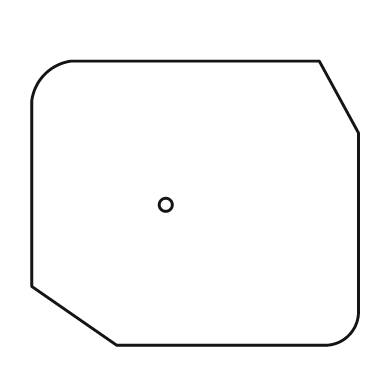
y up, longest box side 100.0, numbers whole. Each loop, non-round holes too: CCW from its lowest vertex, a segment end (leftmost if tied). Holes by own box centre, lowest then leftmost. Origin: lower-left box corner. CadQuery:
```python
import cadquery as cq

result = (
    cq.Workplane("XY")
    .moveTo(26.0, 0.0)
    .lineTo(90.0, 0.0)
    .threePointArc((97.0, 3.0), (100.0, 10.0))
    .lineTo(100.0, 65.0)
    .lineTo(88.0, 87.0)
    .lineTo(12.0, 87.0)
    .threePointArc((4.0, 83.0), (0.0, 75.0))
    .lineTo(0.0, 18.0)
    .close()
    .moveTo(41.0, 43.0)
    .circle(2.0)
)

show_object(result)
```